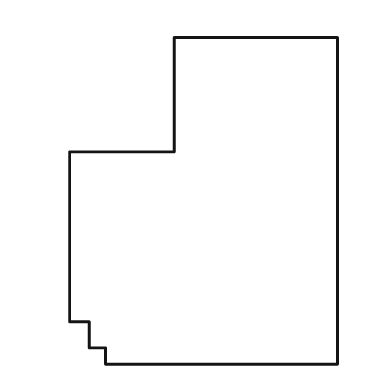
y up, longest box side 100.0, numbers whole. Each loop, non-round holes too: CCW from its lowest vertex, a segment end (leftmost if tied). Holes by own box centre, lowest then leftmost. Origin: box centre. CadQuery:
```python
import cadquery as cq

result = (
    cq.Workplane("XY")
    .moveTo(-30.0, -50.0)
    .lineTo(41.0, -50.0)
    .lineTo(41.0, 50.0)
    .lineTo(-9.0, 50.0)
    .lineTo(-9.0, 15.0)
    .lineTo(-41.0, 15.0)
    .lineTo(-41.0, -37.0)
    .lineTo(-35.0, -37.0)
    .lineTo(-35.0, -45.0)
    .lineTo(-30.0, -45.0)
    .close()
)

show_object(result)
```